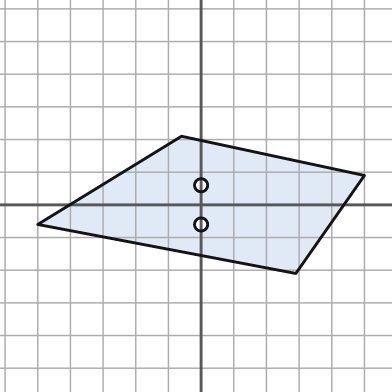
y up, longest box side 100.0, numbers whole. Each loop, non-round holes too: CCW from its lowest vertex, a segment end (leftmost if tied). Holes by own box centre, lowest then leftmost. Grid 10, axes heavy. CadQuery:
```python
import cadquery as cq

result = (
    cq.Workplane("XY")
    .moveTo(29.0, -21.0)
    .lineTo(50.0, 9.0)
    .lineTo(-6.0, 21.0)
    .lineTo(-50.0, -6.0)
    .close()
    .moveTo(0.0, -6.0)
    .circle(2.0)
    .moveTo(0.0, 6.0)
    .circle(2.0)
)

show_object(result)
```